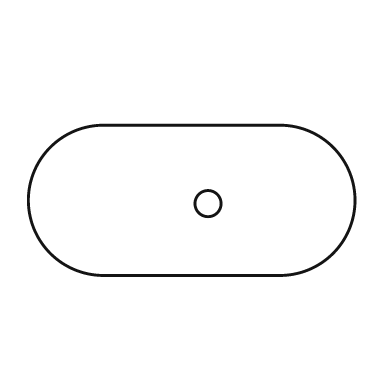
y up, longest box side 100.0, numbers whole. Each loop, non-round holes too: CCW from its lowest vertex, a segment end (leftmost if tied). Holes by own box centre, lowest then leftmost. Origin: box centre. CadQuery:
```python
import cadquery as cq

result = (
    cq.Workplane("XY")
    .moveTo(-27.0, -23.0)
    .lineTo(27.0, -23.0)
    .threePointArc((50.0, 0.0), (27.0, 23.0))
    .lineTo(-27.0, 23.0)
    .threePointArc((-50.0, 0.0), (-27.0, -23.0))
    .close()
    .moveTo(5.0, -1.0)
    .circle(4.0)
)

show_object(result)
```